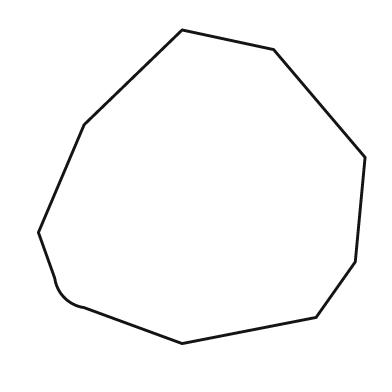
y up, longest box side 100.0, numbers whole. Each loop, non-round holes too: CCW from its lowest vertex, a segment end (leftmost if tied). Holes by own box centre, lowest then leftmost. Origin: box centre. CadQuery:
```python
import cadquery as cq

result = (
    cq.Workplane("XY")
    .moveTo(-6.0, -48.0)
    .lineTo(35.0, -40.0)
    .lineTo(47.0, -23.0)
    .lineTo(50.0, 9.0)
    .lineTo(22.0, 42.0)
    .lineTo(-6.0, 48.0)
    .lineTo(-36.0, 19.0)
    .lineTo(-50.0, -14.0)
    .lineTo(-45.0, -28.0)
    .threePointArc((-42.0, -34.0), (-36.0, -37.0))
    .close()
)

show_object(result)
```